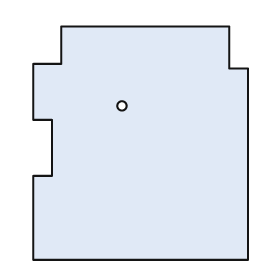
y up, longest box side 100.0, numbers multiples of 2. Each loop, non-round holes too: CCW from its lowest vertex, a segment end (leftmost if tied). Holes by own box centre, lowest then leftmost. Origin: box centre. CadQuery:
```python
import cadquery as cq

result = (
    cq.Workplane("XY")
    .moveTo(-46.0, -50.0)
    .lineTo(46.0, -50.0)
    .lineTo(46.0, 32.0)
    .lineTo(38.0, 32.0)
    .lineTo(38.0, 50.0)
    .lineTo(-34.0, 50.0)
    .lineTo(-34.0, 34.0)
    .lineTo(-46.0, 34.0)
    .lineTo(-46.0, 10.0)
    .lineTo(-38.0, 10.0)
    .lineTo(-38.0, -14.0)
    .lineTo(-46.0, -14.0)
    .close()
    .moveTo(-8.0, 16.0)
    .circle(2.0)
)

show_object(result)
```